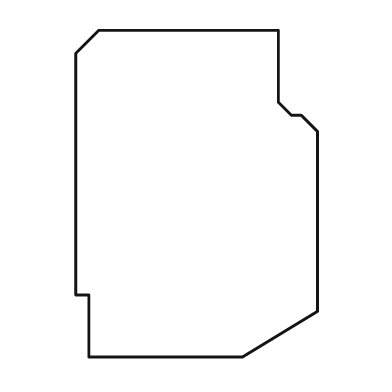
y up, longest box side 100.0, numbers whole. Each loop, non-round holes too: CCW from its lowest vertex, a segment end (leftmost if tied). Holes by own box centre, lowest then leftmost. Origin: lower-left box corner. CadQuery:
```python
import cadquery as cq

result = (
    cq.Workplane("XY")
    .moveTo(4.0, 0.0)
    .lineTo(51.0, 0.0)
    .lineTo(74.0, 14.0)
    .lineTo(74.0, 69.0)
    .lineTo(69.0, 74.0)
    .lineTo(66.0, 74.0)
    .lineTo(62.0, 78.0)
    .lineTo(62.0, 100.0)
    .lineTo(7.0, 100.0)
    .lineTo(0.0, 93.0)
    .lineTo(0.0, 19.0)
    .lineTo(4.0, 19.0)
    .close()
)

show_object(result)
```